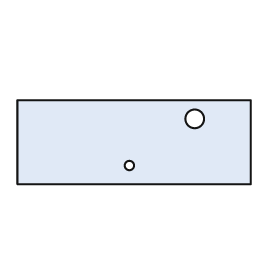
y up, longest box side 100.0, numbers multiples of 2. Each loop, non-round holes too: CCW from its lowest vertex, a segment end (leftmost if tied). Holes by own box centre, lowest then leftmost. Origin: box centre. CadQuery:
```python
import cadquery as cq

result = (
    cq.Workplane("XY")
    .moveTo(-50.0, -18.0)
    .lineTo(50.0, -18.0)
    .lineTo(50.0, 18.0)
    .lineTo(-50.0, 18.0)
    .close()
    .moveTo(-2.0, -10.0)
    .circle(2.0)
    .moveTo(26.0, 10.0)
    .circle(4.0)
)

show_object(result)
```